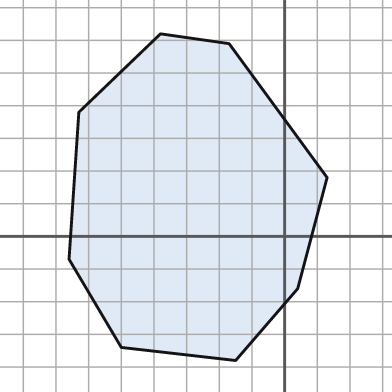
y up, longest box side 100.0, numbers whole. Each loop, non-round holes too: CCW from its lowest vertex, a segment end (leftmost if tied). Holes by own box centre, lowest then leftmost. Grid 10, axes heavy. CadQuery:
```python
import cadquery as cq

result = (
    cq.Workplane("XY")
    .moveTo(-15.0, -38.0)
    .lineTo(4.0, -16.0)
    .lineTo(13.0, 18.0)
    .lineTo(-17.0, 59.0)
    .lineTo(-38.0, 62.0)
    .lineTo(-63.0, 38.0)
    .lineTo(-66.0, -7.0)
    .lineTo(-50.0, -34.0)
    .close()
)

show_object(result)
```